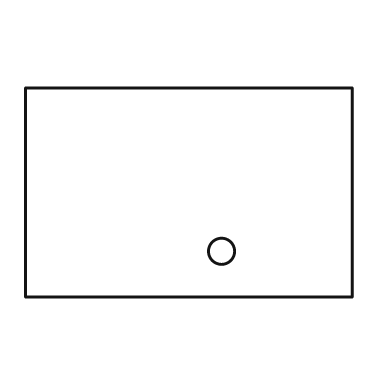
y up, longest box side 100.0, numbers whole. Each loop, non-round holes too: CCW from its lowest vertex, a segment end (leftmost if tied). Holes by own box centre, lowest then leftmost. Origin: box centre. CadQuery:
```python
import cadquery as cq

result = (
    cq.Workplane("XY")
    .moveTo(-50.0, -32.0)
    .lineTo(50.0, -32.0)
    .lineTo(50.0, 32.0)
    .lineTo(-50.0, 32.0)
    .close()
    .moveTo(10.0, -18.0)
    .circle(4.0)
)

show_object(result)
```